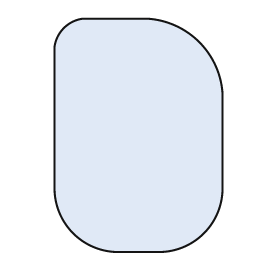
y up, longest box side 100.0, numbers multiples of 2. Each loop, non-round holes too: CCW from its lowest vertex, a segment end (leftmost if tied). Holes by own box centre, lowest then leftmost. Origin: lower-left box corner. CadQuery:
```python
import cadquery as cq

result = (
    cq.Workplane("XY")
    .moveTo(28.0, 0.0)
    .lineTo(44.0, 0.0)
    .threePointArc((64.0, 8.0), (72.0, 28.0))
    .lineTo(72.0, 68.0)
    .threePointArc((62.0, 90.0), (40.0, 100.0))
    .lineTo(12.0, 100.0)
    .threePointArc((4.0, 96.0), (0.0, 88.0))
    .lineTo(0.0, 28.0)
    .threePointArc((8.0, 8.0), (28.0, 0.0))
    .close()
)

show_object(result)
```